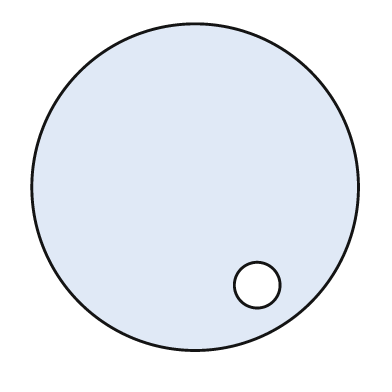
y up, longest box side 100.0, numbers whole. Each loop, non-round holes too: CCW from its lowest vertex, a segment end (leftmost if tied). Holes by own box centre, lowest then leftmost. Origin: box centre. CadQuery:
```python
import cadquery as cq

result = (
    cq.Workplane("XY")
    .moveTo(0.0, 0.0)
    .circle(50.0)
    .moveTo(19.0, -30.0)
    .circle(7.0)
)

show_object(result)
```